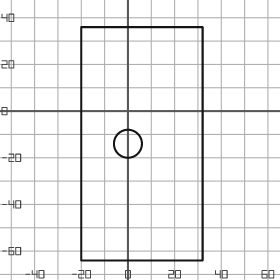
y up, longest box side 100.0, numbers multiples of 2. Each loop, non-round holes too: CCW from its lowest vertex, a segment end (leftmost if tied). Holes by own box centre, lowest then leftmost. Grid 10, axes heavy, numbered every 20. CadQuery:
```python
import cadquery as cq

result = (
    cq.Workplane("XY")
    .moveTo(-20.0, -64.0)
    .lineTo(32.0, -64.0)
    .lineTo(32.0, 36.0)
    .lineTo(-20.0, 36.0)
    .close()
    .moveTo(0.0, -14.0)
    .circle(6.0)
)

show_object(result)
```